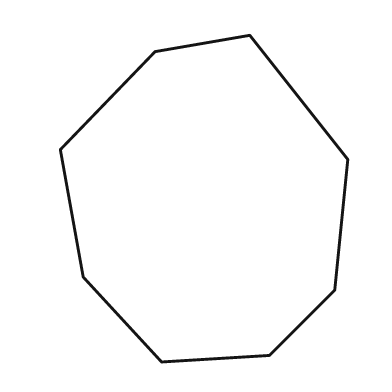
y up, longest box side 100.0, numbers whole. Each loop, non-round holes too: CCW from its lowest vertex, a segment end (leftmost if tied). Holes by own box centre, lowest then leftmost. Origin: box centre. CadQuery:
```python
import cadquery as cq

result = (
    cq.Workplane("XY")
    .moveTo(-13.0, -50.0)
    .lineTo(20.0, -48.0)
    .lineTo(40.0, -28.0)
    .lineTo(44.0, 12.0)
    .lineTo(14.0, 50.0)
    .lineTo(-15.0, 45.0)
    .lineTo(-44.0, 15.0)
    .lineTo(-37.0, -24.0)
    .close()
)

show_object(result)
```